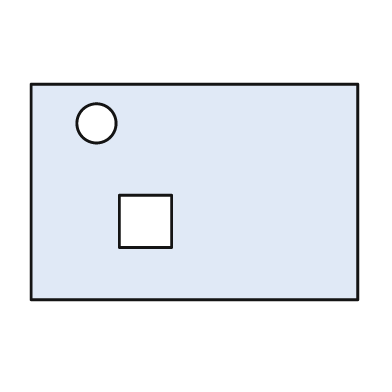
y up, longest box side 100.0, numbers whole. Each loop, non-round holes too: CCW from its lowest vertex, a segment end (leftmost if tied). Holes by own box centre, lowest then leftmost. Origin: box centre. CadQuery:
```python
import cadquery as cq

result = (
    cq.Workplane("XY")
    .moveTo(-50.0, -33.0)
    .lineTo(50.0, -33.0)
    .lineTo(50.0, 33.0)
    .lineTo(-50.0, 33.0)
    .close()
    .moveTo(-23.0, -17.0)
    .lineTo(-7.0, -17.0)
    .lineTo(-7.0, -1.0)
    .lineTo(-23.0, -1.0)
    .close()
    .moveTo(-30.0, 21.0)
    .circle(6.0)
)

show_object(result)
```